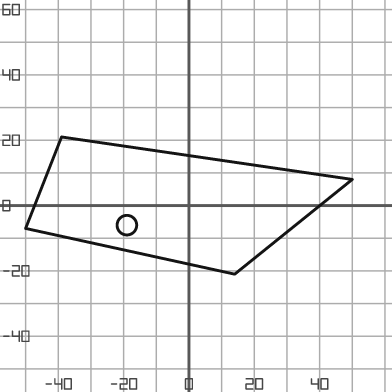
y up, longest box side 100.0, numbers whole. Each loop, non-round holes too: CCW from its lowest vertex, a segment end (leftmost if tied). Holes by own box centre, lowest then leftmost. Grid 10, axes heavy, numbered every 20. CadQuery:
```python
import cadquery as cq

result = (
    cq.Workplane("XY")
    .moveTo(14.0, -21.0)
    .lineTo(50.0, 8.0)
    .lineTo(-39.0, 21.0)
    .lineTo(-50.0, -7.0)
    .close()
    .moveTo(-19.0, -6.0)
    .circle(3.0)
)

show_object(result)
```